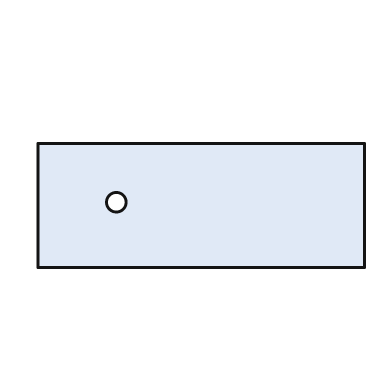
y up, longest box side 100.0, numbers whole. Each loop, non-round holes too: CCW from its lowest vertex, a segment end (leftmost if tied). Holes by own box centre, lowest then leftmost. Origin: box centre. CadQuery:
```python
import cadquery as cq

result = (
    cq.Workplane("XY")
    .moveTo(-50.0, -19.0)
    .lineTo(50.0, -19.0)
    .lineTo(50.0, 19.0)
    .lineTo(-50.0, 19.0)
    .close()
    .moveTo(-26.0, 1.0)
    .circle(3.0)
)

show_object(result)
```